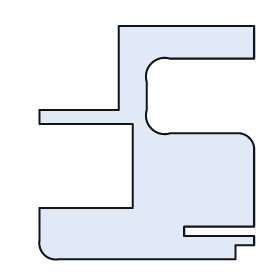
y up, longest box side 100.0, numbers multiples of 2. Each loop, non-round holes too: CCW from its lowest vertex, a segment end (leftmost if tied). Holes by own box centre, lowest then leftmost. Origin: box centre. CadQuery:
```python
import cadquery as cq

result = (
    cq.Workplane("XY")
    .moveTo(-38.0, -50.0)
    .lineTo(38.0, -50.0)
    .lineTo(38.0, -44.0)
    .lineTo(46.0, -44.0)
    .lineTo(46.0, -40.0)
    .lineTo(16.0, -40.0)
    .lineTo(16.0, -36.0)
    .lineTo(46.0, -36.0)
    .lineTo(46.0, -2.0)
    .threePointArc((44.0, 2.0), (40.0, 4.0))
    .lineTo(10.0, 4.0)
    .threePointArc((2.0, 6.0), (0.0, 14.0))
    .lineTo(0.0, 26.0)
    .threePointArc((2.0, 34.0), (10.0, 36.0))
    .lineTo(46.0, 36.0)
    .lineTo(46.0, 50.0)
    .lineTo(-12.0, 50.0)
    .lineTo(-12.0, 14.0)
    .lineTo(-46.0, 14.0)
    .lineTo(-46.0, 8.0)
    .lineTo(-6.0, 8.0)
    .lineTo(-6.0, -28.0)
    .lineTo(-46.0, -28.0)
    .lineTo(-46.0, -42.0)
    .threePointArc((-44.0, -48.0), (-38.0, -50.0))
    .close()
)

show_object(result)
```